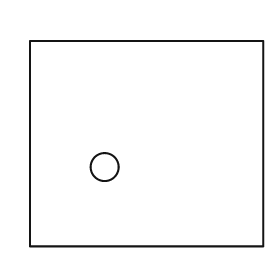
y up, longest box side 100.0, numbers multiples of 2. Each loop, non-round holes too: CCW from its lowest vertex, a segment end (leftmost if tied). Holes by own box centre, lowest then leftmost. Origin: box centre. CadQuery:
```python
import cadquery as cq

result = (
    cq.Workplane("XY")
    .moveTo(-50.0, -44.0)
    .lineTo(50.0, -44.0)
    .lineTo(50.0, 44.0)
    .lineTo(-50.0, 44.0)
    .close()
    .moveTo(-18.0, -10.0)
    .circle(6.0)
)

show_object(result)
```